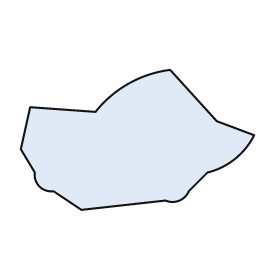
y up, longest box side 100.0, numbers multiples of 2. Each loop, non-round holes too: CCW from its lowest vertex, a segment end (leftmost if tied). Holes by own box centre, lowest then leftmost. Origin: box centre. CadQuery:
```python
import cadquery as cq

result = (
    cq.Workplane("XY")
    .moveTo(-24.0, -30.0)
    .lineTo(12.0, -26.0)
    .threePointArc((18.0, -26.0), (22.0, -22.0))
    .lineTo(30.0, -14.0)
    .threePointArc((42.0, -8.0), (50.0, 2.0))
    .lineTo(34.0, 8.0)
    .lineTo(14.0, 30.0)
    .threePointArc((-4.0, 24.0), (-18.0, 12.0))
    .lineTo(-46.0, 14.0)
    .lineTo(-50.0, -4.0)
    .lineTo(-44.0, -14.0)
    .threePointArc((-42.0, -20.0), (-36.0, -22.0))
    .close()
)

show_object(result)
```